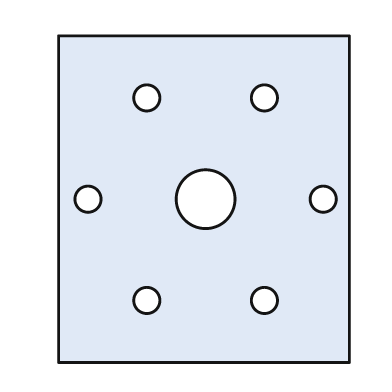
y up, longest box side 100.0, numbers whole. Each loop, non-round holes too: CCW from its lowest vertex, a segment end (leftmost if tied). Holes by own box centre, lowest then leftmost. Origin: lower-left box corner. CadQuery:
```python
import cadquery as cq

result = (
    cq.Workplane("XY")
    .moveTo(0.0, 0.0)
    .lineTo(89.0, 0.0)
    .lineTo(89.0, 100.0)
    .lineTo(0.0, 100.0)
    .close()
    .moveTo(27.0, 19.0)
    .circle(4.0)
    .moveTo(63.0, 19.0)
    .circle(4.0)
    .moveTo(9.0, 50.0)
    .circle(4.0)
    .moveTo(45.0, 50.0)
    .circle(9.0)
    .moveTo(81.0, 50.0)
    .circle(4.0)
    .moveTo(27.0, 81.0)
    .circle(4.0)
    .moveTo(63.0, 81.0)
    .circle(4.0)
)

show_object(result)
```